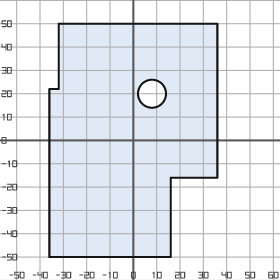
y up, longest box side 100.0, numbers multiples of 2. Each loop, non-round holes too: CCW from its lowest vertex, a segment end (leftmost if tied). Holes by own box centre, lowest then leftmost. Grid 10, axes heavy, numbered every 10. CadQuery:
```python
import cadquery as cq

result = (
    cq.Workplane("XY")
    .moveTo(-36.0, -50.0)
    .lineTo(16.0, -50.0)
    .lineTo(16.0, -16.0)
    .lineTo(36.0, -16.0)
    .lineTo(36.0, 50.0)
    .lineTo(-32.0, 50.0)
    .lineTo(-32.0, 22.0)
    .lineTo(-36.0, 22.0)
    .close()
    .moveTo(8.0, 20.0)
    .circle(6.0)
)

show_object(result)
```